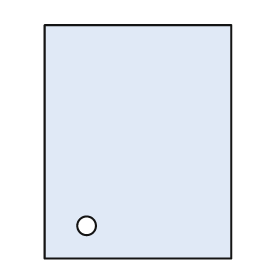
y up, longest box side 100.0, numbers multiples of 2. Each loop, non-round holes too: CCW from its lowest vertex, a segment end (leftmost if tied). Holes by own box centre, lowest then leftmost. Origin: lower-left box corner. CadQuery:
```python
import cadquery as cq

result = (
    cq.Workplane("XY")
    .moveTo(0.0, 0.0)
    .lineTo(80.0, 0.0)
    .lineTo(80.0, 100.0)
    .lineTo(0.0, 100.0)
    .close()
    .moveTo(18.0, 14.0)
    .circle(4.0)
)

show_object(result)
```